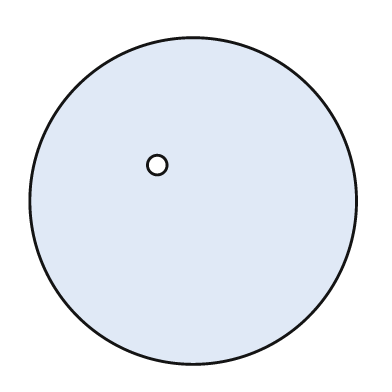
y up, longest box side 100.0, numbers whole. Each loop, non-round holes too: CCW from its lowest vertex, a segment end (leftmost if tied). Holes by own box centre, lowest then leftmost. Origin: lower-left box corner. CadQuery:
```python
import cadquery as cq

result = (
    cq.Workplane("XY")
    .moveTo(50.0, 50.0)
    .circle(50.0)
    .moveTo(39.0, 61.0)
    .circle(3.0)
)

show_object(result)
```